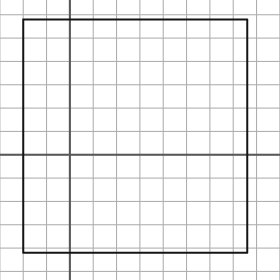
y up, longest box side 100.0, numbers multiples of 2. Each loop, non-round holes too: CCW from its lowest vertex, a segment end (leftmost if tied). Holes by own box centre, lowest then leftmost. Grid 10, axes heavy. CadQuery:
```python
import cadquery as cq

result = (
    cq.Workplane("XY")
    .moveTo(-20.0, -42.0)
    .lineTo(76.0, -42.0)
    .lineTo(76.0, 58.0)
    .lineTo(-20.0, 58.0)
    .close()
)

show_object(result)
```